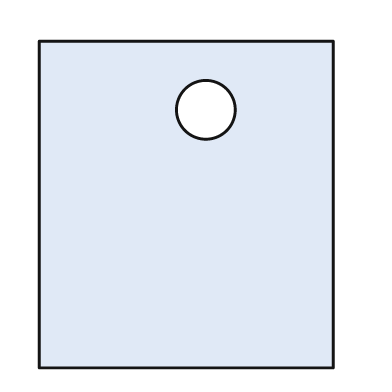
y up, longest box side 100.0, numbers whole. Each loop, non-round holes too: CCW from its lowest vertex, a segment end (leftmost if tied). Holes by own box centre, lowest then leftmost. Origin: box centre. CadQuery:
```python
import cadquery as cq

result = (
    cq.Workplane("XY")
    .moveTo(-45.0, -50.0)
    .lineTo(45.0, -50.0)
    .lineTo(45.0, 50.0)
    .lineTo(-45.0, 50.0)
    .close()
    .moveTo(6.0, 29.0)
    .circle(9.0)
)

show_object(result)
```